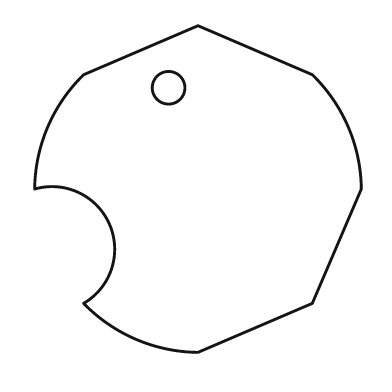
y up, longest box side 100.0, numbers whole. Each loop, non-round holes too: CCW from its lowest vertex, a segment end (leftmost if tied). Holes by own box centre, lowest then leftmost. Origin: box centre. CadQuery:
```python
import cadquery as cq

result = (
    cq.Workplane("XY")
    .moveTo(0.0, -50.0)
    .lineTo(35.0, -35.0)
    .lineTo(50.0, 0.0)
    .threePointArc((46.0, 19.0), (35.0, 35.0))
    .lineTo(0.0, 50.0)
    .lineTo(-35.0, 35.0)
    .threePointArc((-46.0, 19.0), (-50.0, 0.0))
    .threePointArc((-27.0, -11.0), (-35.0, -35.0))
    .threePointArc((-19.0, -46.0), (0.0, -50.0))
    .close()
    .moveTo(-9.0, 31.0)
    .circle(5.0)
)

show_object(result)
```